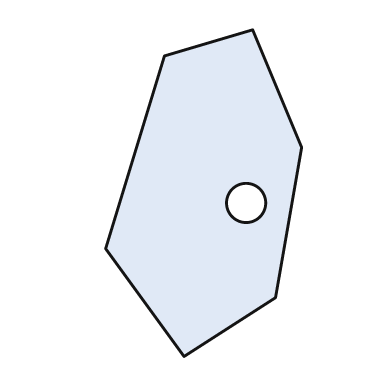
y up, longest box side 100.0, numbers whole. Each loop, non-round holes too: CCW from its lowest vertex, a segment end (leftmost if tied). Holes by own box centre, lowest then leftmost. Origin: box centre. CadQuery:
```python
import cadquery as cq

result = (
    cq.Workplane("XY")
    .moveTo(-6.0, -50.0)
    .lineTo(22.0, -32.0)
    .lineTo(30.0, 14.0)
    .lineTo(15.0, 50.0)
    .lineTo(-12.0, 42.0)
    .lineTo(-30.0, -17.0)
    .close()
    .moveTo(13.0, -3.0)
    .circle(6.0)
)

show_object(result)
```